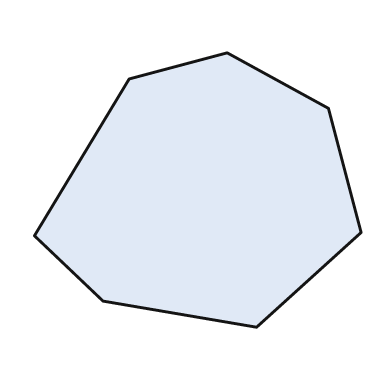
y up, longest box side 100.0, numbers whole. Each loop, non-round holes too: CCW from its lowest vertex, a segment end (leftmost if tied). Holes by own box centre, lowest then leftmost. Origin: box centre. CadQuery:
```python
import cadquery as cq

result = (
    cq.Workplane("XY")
    .moveTo(18.0, -42.0)
    .lineTo(50.0, -13.0)
    .lineTo(40.0, 25.0)
    .lineTo(9.0, 42.0)
    .lineTo(-21.0, 34.0)
    .lineTo(-50.0, -14.0)
    .lineTo(-29.0, -34.0)
    .close()
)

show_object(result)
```